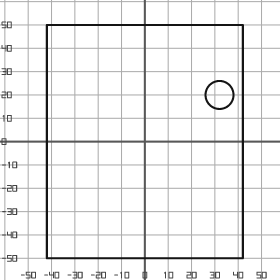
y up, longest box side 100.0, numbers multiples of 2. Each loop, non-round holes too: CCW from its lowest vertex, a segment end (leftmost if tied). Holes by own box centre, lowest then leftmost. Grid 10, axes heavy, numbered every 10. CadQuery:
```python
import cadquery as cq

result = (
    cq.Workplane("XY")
    .moveTo(-42.0, -50.0)
    .lineTo(42.0, -50.0)
    .lineTo(42.0, 50.0)
    .lineTo(-42.0, 50.0)
    .close()
    .moveTo(32.0, 20.0)
    .circle(6.0)
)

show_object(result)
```